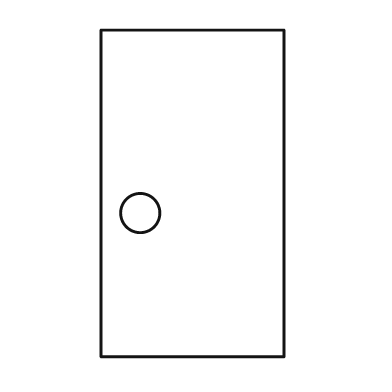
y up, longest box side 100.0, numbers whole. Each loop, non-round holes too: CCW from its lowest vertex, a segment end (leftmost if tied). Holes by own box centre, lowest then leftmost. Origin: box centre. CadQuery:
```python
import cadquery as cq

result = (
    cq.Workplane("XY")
    .moveTo(-28.0, -50.0)
    .lineTo(28.0, -50.0)
    .lineTo(28.0, 50.0)
    .lineTo(-28.0, 50.0)
    .close()
    .moveTo(-16.0, -6.0)
    .circle(6.0)
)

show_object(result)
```